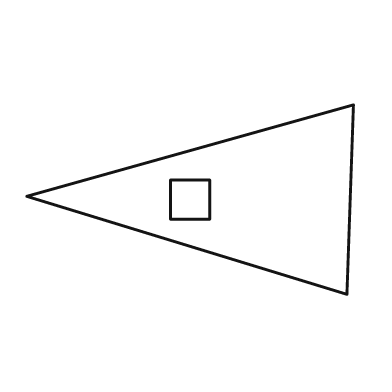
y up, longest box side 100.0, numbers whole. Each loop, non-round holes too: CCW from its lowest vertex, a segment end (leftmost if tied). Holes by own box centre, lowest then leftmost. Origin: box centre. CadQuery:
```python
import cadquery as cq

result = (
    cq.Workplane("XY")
    .moveTo(48.0, -29.0)
    .lineTo(50.0, 29.0)
    .lineTo(-50.0, 1.0)
    .close()
    .moveTo(-6.0, -6.0)
    .lineTo(6.0, -6.0)
    .lineTo(6.0, 6.0)
    .lineTo(-6.0, 6.0)
    .close()
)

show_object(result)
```